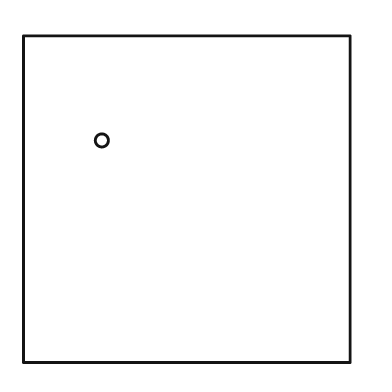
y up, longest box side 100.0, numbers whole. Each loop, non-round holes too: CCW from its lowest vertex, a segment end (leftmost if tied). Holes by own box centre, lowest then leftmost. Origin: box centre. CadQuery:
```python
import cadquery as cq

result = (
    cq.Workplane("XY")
    .moveTo(-50.0, -50.0)
    .lineTo(50.0, -50.0)
    .lineTo(50.0, 50.0)
    .lineTo(-50.0, 50.0)
    .close()
    .moveTo(-26.0, 18.0)
    .circle(2.0)
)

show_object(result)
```